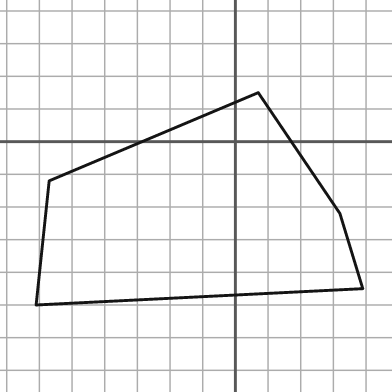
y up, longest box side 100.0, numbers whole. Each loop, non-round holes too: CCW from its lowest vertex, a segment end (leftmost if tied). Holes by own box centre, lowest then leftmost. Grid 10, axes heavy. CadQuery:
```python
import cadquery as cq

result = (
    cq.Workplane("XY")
    .moveTo(-61.0, -50.0)
    .lineTo(39.0, -45.0)
    .lineTo(32.0, -22.0)
    .lineTo(7.0, 15.0)
    .lineTo(-57.0, -12.0)
    .close()
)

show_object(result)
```